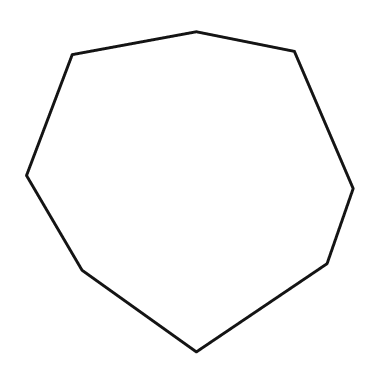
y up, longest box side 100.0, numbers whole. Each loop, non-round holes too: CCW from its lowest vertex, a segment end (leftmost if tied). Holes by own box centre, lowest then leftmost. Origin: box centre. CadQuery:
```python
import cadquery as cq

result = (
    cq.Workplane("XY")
    .moveTo(2.0, -49.0)
    .lineTo(42.0, -22.0)
    .lineTo(50.0, 1.0)
    .lineTo(32.0, 43.0)
    .lineTo(2.0, 49.0)
    .lineTo(-36.0, 42.0)
    .lineTo(-50.0, 5.0)
    .lineTo(-33.0, -24.0)
    .close()
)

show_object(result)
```